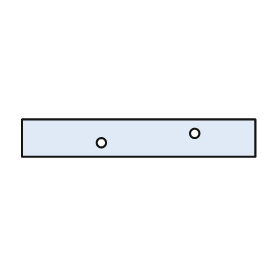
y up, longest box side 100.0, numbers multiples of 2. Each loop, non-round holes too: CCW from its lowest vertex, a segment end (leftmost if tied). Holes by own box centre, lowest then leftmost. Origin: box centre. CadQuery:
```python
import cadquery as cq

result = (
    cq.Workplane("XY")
    .moveTo(-50.0, -8.0)
    .lineTo(50.0, -8.0)
    .lineTo(50.0, 8.0)
    .lineTo(-50.0, 8.0)
    .close()
    .moveTo(-16.0, -2.0)
    .circle(2.0)
    .moveTo(24.0, 2.0)
    .circle(2.0)
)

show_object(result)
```